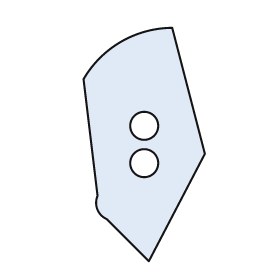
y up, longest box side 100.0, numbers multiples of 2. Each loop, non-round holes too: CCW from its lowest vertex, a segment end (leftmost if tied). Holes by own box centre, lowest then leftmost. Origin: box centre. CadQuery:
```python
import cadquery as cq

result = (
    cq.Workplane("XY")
    .moveTo(2.0, -50.0)
    .lineTo(26.0, -4.0)
    .lineTo(12.0, 50.0)
    .threePointArc((-10.0, 44.0), (-26.0, 28.0))
    .lineTo(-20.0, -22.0)
    .threePointArc((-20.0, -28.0), (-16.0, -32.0))
    .close()
    .moveTo(0.0, -8.0)
    .circle(6.0)
    .moveTo(0.0, 8.0)
    .circle(6.0)
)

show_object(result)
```